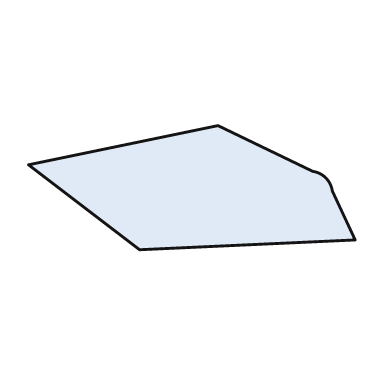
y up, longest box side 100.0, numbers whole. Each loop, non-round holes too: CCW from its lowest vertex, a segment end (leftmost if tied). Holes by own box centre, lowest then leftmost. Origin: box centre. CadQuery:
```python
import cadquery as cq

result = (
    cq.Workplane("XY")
    .moveTo(-16.0, -19.0)
    .lineTo(50.0, -16.0)
    .lineTo(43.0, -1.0)
    .threePointArc((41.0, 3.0), (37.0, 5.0))
    .lineTo(8.0, 19.0)
    .lineTo(-50.0, 7.0)
    .close()
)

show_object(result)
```